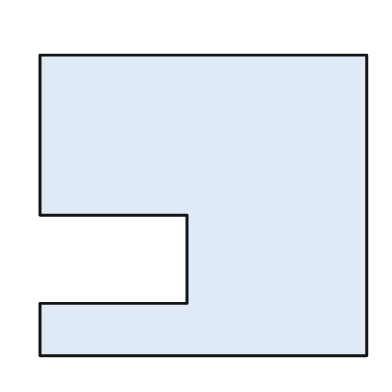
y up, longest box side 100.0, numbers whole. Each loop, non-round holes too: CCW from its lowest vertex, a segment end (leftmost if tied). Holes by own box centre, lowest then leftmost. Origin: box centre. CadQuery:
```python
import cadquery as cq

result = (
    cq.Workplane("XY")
    .moveTo(-50.0, -46.0)
    .lineTo(50.0, -46.0)
    .lineTo(50.0, 46.0)
    .lineTo(-50.0, 46.0)
    .lineTo(-50.0, -3.0)
    .lineTo(-5.0, -3.0)
    .lineTo(-5.0, -30.0)
    .lineTo(-50.0, -30.0)
    .close()
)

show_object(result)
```